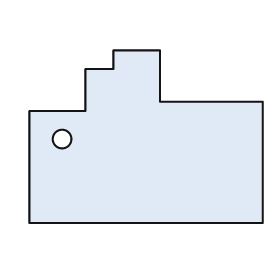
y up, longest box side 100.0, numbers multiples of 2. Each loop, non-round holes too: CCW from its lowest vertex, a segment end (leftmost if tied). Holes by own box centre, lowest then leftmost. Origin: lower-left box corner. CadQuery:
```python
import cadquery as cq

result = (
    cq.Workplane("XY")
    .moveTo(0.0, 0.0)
    .lineTo(100.0, 0.0)
    .lineTo(100.0, 52.0)
    .lineTo(56.0, 52.0)
    .lineTo(56.0, 74.0)
    .lineTo(36.0, 74.0)
    .lineTo(36.0, 66.0)
    .lineTo(24.0, 66.0)
    .lineTo(24.0, 48.0)
    .lineTo(0.0, 48.0)
    .close()
    .moveTo(14.0, 36.0)
    .circle(4.0)
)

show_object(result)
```